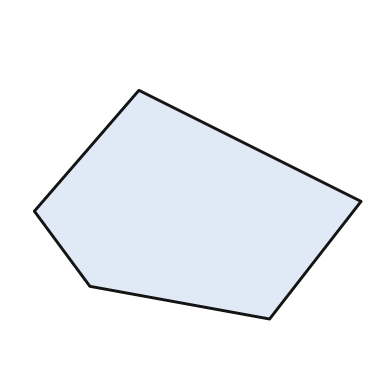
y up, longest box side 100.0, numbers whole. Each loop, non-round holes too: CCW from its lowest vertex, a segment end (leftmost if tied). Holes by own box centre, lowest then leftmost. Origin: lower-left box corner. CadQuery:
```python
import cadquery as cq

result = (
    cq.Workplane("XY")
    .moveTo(72.0, 0.0)
    .lineTo(100.0, 36.0)
    .lineTo(32.0, 70.0)
    .lineTo(0.0, 33.0)
    .lineTo(17.0, 10.0)
    .close()
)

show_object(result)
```